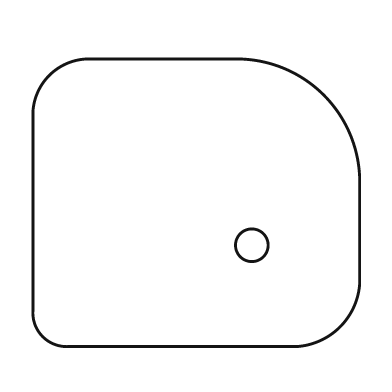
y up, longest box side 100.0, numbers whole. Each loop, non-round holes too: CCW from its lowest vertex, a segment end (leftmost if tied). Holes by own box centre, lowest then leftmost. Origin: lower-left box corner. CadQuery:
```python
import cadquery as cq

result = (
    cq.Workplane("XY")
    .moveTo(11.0, 0.0)
    .lineTo(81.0, 0.0)
    .threePointArc((94.0, 6.0), (100.0, 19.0))
    .lineTo(100.0, 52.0)
    .threePointArc((89.0, 77.0), (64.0, 88.0))
    .lineTo(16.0, 88.0)
    .threePointArc((5.0, 83.0), (0.0, 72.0))
    .lineTo(0.0, 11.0)
    .threePointArc((3.0, 3.0), (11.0, 0.0))
    .close()
    .moveTo(67.0, 31.0)
    .circle(5.0)
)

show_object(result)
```